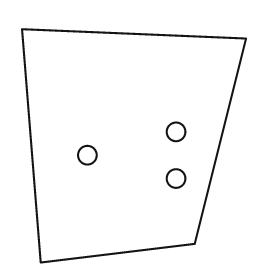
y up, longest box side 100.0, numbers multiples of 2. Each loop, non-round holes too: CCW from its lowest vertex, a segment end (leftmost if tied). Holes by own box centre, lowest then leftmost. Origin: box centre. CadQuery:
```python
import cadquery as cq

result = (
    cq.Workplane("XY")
    .moveTo(-40.0, -50.0)
    .lineTo(26.0, -42.0)
    .lineTo(48.0, 46.0)
    .lineTo(-48.0, 50.0)
    .close()
    .moveTo(18.0, -14.0)
    .circle(4.0)
    .moveTo(-20.0, -4.0)
    .circle(4.0)
    .moveTo(18.0, 6.0)
    .circle(4.0)
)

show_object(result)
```